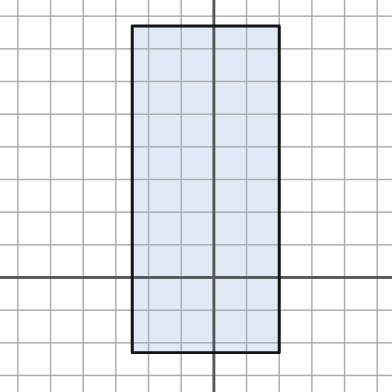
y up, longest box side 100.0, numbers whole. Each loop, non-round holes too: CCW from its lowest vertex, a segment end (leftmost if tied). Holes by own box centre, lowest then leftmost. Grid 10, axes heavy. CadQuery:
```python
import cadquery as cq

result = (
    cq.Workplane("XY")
    .moveTo(-25.0, -23.0)
    .lineTo(20.0, -23.0)
    .lineTo(20.0, 77.0)
    .lineTo(-25.0, 77.0)
    .close()
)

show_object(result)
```